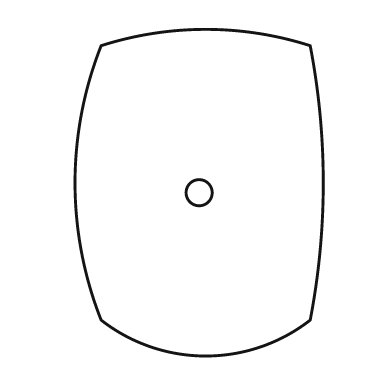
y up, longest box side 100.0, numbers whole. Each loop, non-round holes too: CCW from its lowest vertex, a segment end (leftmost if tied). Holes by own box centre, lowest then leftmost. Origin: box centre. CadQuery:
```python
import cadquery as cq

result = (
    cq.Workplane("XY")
    .moveTo(-30.0, -39.0)
    .threePointArc((2.0, -50.0), (34.0, -39.0))
    .threePointArc((38.0, 3.0), (34.0, 45.0))
    .threePointArc((2.0, 50.0), (-30.0, 45.0))
    .threePointArc((-38.0, 3.0), (-30.0, -39.0))
    .close()
    .moveTo(0.0, 0.0)
    .circle(4.0)
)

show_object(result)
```